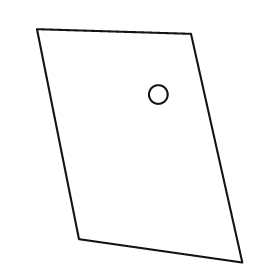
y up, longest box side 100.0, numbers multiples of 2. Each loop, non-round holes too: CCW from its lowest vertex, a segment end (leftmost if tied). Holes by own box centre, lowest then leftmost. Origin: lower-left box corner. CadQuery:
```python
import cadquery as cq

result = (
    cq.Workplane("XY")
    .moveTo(88.0, 0.0)
    .lineTo(66.0, 98.0)
    .lineTo(0.0, 100.0)
    .lineTo(18.0, 10.0)
    .close()
    .moveTo(52.0, 72.0)
    .circle(4.0)
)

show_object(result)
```